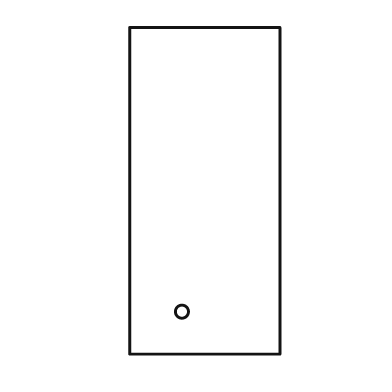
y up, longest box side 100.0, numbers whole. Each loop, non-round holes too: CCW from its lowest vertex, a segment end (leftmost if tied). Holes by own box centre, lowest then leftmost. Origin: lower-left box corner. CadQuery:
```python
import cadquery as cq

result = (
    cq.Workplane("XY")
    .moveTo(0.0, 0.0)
    .lineTo(46.0, 0.0)
    .lineTo(46.0, 100.0)
    .lineTo(0.0, 100.0)
    .close()
    .moveTo(16.0, 13.0)
    .circle(2.0)
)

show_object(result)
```